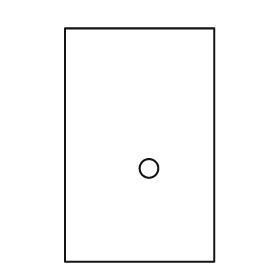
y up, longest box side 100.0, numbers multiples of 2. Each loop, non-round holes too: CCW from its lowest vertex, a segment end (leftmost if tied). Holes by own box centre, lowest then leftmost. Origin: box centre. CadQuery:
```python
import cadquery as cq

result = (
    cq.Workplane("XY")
    .moveTo(-32.0, -50.0)
    .lineTo(32.0, -50.0)
    .lineTo(32.0, 50.0)
    .lineTo(-32.0, 50.0)
    .close()
    .moveTo(4.0, -10.0)
    .circle(4.0)
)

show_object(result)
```